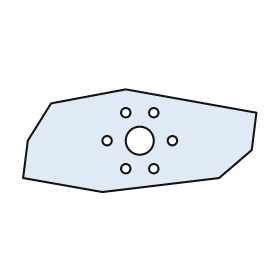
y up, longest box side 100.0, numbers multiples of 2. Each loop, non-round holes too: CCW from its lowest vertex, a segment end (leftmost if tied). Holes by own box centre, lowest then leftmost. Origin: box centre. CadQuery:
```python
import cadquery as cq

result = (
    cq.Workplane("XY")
    .moveTo(-16.0, -22.0)
    .lineTo(34.0, -16.0)
    .lineTo(48.0, -4.0)
    .lineTo(50.0, 12.0)
    .lineTo(-6.0, 22.0)
    .lineTo(-38.0, 16.0)
    .lineTo(-48.0, 0.0)
    .lineTo(-50.0, -16.0)
    .close()
    .moveTo(-6.0, -12.0)
    .circle(2.0)
    .moveTo(6.0, -12.0)
    .circle(2.0)
    .moveTo(-14.0, 0.0)
    .circle(2.0)
    .moveTo(0.0, 0.0)
    .circle(6.0)
    .moveTo(14.0, 0.0)
    .circle(2.0)
    .moveTo(-6.0, 12.0)
    .circle(2.0)
    .moveTo(6.0, 12.0)
    .circle(2.0)
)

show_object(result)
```